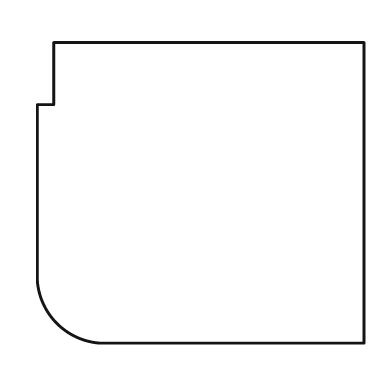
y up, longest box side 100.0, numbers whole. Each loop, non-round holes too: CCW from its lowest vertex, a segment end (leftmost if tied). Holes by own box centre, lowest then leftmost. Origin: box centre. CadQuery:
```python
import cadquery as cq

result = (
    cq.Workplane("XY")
    .moveTo(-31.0, -46.0)
    .lineTo(50.0, -46.0)
    .lineTo(50.0, 46.0)
    .lineTo(-45.0, 46.0)
    .lineTo(-45.0, 27.0)
    .lineTo(-50.0, 27.0)
    .lineTo(-50.0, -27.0)
    .threePointArc((-44.0, -40.0), (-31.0, -46.0))
    .close()
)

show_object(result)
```